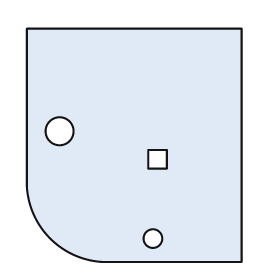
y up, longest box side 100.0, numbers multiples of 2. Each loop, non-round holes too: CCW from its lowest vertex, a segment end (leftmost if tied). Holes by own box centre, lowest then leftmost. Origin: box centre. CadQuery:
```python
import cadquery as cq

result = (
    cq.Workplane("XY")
    .moveTo(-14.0, -50.0)
    .lineTo(46.0, -50.0)
    .lineTo(46.0, 50.0)
    .lineTo(-46.0, 50.0)
    .lineTo(-46.0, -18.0)
    .threePointArc((-36.0, -40.0), (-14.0, -50.0))
    .close()
    .moveTo(8.0, -40.0)
    .circle(4.0)
    .moveTo(6.0, -10.0)
    .lineTo(14.0, -10.0)
    .lineTo(14.0, -2.0)
    .lineTo(6.0, -2.0)
    .close()
    .moveTo(-32.0, 6.0)
    .circle(6.0)
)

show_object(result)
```